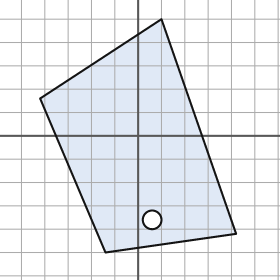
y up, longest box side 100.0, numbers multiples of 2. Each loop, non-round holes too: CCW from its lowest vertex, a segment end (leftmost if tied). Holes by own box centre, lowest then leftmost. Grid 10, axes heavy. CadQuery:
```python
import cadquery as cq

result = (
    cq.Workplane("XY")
    .moveTo(-14.0, -50.0)
    .lineTo(42.0, -42.0)
    .lineTo(10.0, 50.0)
    .lineTo(-42.0, 16.0)
    .close()
    .moveTo(6.0, -36.0)
    .circle(4.0)
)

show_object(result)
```